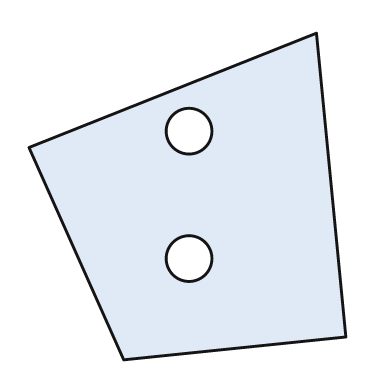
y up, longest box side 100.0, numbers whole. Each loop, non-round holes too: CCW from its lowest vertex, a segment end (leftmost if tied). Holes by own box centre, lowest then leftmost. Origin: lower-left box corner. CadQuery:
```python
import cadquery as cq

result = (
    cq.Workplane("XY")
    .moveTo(29.0, 0.0)
    .lineTo(97.0, 7.0)
    .lineTo(88.0, 100.0)
    .lineTo(0.0, 65.0)
    .close()
    .moveTo(49.0, 31.0)
    .circle(7.0)
    .moveTo(49.0, 70.0)
    .circle(7.0)
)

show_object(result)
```